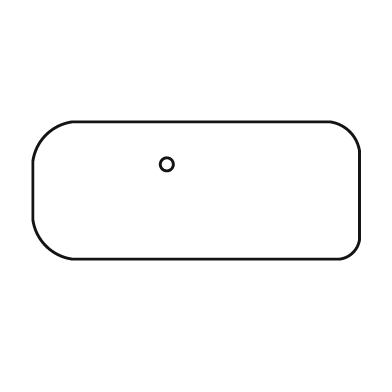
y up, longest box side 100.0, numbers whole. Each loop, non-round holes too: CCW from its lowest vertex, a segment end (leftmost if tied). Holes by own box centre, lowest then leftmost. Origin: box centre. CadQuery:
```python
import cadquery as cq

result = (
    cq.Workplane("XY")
    .moveTo(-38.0, -21.0)
    .lineTo(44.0, -21.0)
    .threePointArc((48.0, -19.0), (50.0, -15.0))
    .lineTo(50.0, 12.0)
    .threePointArc((47.0, 18.0), (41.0, 21.0))
    .lineTo(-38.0, 21.0)
    .threePointArc((-46.0, 17.0), (-50.0, 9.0))
    .lineTo(-50.0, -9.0)
    .threePointArc((-46.0, -17.0), (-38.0, -21.0))
    .close()
    .moveTo(-9.0, 8.0)
    .circle(2.0)
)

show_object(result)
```